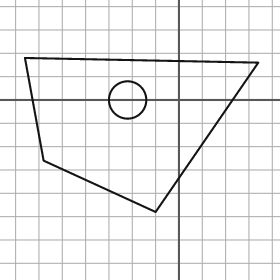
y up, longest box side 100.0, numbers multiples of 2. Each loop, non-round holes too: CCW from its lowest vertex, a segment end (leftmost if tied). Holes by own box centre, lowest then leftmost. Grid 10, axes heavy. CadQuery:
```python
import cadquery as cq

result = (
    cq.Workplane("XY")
    .moveTo(-10.0, -48.0)
    .lineTo(34.0, 16.0)
    .lineTo(-66.0, 18.0)
    .lineTo(-58.0, -26.0)
    .close()
    .moveTo(-22.0, 0.0)
    .circle(8.0)
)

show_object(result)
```